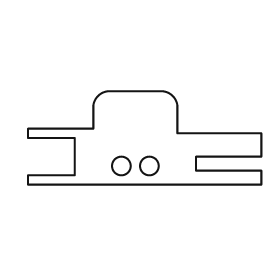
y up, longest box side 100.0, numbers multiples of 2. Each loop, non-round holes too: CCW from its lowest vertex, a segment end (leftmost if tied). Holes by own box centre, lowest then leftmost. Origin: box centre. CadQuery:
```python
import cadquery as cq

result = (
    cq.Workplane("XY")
    .moveTo(-50.0, -20.0)
    .lineTo(50.0, -20.0)
    .lineTo(50.0, -14.0)
    .lineTo(22.0, -14.0)
    .lineTo(22.0, -8.0)
    .lineTo(50.0, -8.0)
    .lineTo(50.0, 2.0)
    .lineTo(14.0, 2.0)
    .lineTo(14.0, 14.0)
    .threePointArc((12.0, 18.0), (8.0, 20.0))
    .lineTo(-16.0, 20.0)
    .threePointArc((-20.0, 18.0), (-22.0, 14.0))
    .lineTo(-22.0, 4.0)
    .lineTo(-50.0, 4.0)
    .lineTo(-50.0, 0.0)
    .lineTo(-30.0, 0.0)
    .lineTo(-30.0, -16.0)
    .lineTo(-50.0, -16.0)
    .close()
    .moveTo(-10.0, -12.0)
    .circle(4.0)
    .moveTo(2.0, -12.0)
    .circle(4.0)
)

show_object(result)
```